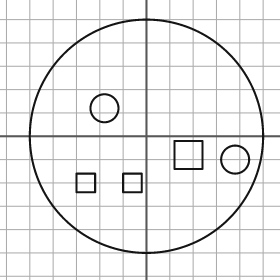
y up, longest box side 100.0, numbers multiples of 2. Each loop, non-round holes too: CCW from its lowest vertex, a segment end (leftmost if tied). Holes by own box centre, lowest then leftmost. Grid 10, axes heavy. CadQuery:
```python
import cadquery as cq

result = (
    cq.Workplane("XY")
    .moveTo(0.0, 0.0)
    .circle(50.0)
    .moveTo(-30.0, -24.0)
    .lineTo(-22.0, -24.0)
    .lineTo(-22.0, -16.0)
    .lineTo(-30.0, -16.0)
    .close()
    .moveTo(-10.0, -24.0)
    .lineTo(-2.0, -24.0)
    .lineTo(-2.0, -16.0)
    .lineTo(-10.0, -16.0)
    .close()
    .moveTo(38.0, -10.0)
    .circle(6.0)
    .moveTo(12.0, -14.0)
    .lineTo(24.0, -14.0)
    .lineTo(24.0, -2.0)
    .lineTo(12.0, -2.0)
    .close()
    .moveTo(-18.0, 12.0)
    .circle(6.0)
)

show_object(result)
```